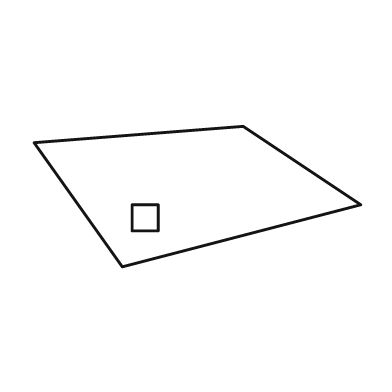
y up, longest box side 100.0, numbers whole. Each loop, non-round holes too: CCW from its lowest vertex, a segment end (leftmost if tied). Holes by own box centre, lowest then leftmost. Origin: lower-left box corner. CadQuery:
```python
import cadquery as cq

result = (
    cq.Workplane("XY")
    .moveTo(27.0, 0.0)
    .lineTo(100.0, 19.0)
    .lineTo(64.0, 43.0)
    .lineTo(0.0, 38.0)
    .close()
    .moveTo(30.0, 11.0)
    .lineTo(38.0, 11.0)
    .lineTo(38.0, 19.0)
    .lineTo(30.0, 19.0)
    .close()
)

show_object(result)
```